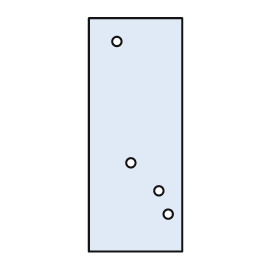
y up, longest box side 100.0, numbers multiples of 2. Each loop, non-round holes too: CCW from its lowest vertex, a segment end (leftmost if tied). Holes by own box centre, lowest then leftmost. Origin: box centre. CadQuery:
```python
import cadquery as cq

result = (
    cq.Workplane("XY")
    .moveTo(-20.0, -50.0)
    .lineTo(20.0, -50.0)
    .lineTo(20.0, 50.0)
    .lineTo(-20.0, 50.0)
    .close()
    .moveTo(14.0, -34.0)
    .circle(2.0)
    .moveTo(10.0, -24.0)
    .circle(2.0)
    .moveTo(-2.0, -12.0)
    .circle(2.0)
    .moveTo(-8.0, 40.0)
    .circle(2.0)
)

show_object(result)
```